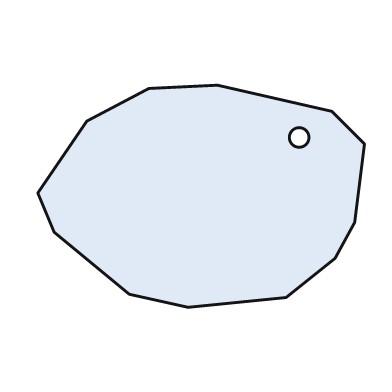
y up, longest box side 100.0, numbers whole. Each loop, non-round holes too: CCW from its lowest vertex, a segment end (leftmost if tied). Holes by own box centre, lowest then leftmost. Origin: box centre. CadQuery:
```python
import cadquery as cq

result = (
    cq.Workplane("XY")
    .moveTo(-4.0, -34.0)
    .lineTo(26.0, -31.0)
    .lineTo(41.0, -19.0)
    .lineTo(47.0, -8.0)
    .lineTo(50.0, 16.0)
    .lineTo(40.0, 26.0)
    .lineTo(5.0, 34.0)
    .lineTo(-16.0, 33.0)
    .lineTo(-35.0, 23.0)
    .lineTo(-50.0, 1.0)
    .lineTo(-45.0, -11.0)
    .lineTo(-22.0, -30.0)
    .close()
    .moveTo(30.0, 18.0)
    .circle(3.0)
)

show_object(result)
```